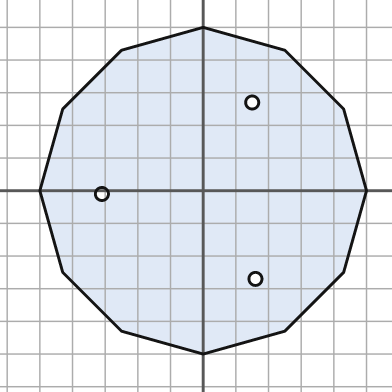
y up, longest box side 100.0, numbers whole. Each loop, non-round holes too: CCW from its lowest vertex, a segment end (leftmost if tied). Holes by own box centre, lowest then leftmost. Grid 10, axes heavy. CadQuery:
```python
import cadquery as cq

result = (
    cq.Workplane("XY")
    .moveTo(0.0, -50.0)
    .lineTo(25.0, -43.0)
    .lineTo(43.0, -25.0)
    .lineTo(50.0, 0.0)
    .lineTo(43.0, 25.0)
    .lineTo(25.0, 43.0)
    .lineTo(0.0, 50.0)
    .lineTo(-25.0, 43.0)
    .lineTo(-43.0, 25.0)
    .lineTo(-50.0, 0.0)
    .lineTo(-43.0, -25.0)
    .lineTo(-25.0, -43.0)
    .close()
    .moveTo(16.0, -27.0)
    .circle(2.0)
    .moveTo(-31.0, -1.0)
    .circle(2.0)
    .moveTo(15.0, 27.0)
    .circle(2.0)
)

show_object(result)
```